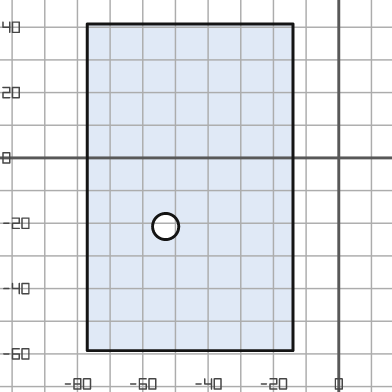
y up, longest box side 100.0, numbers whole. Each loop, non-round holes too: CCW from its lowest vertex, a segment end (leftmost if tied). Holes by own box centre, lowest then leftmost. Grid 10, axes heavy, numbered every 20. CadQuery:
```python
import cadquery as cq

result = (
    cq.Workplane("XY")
    .moveTo(-77.0, -59.0)
    .lineTo(-14.0, -59.0)
    .lineTo(-14.0, 41.0)
    .lineTo(-77.0, 41.0)
    .close()
    .moveTo(-53.0, -21.0)
    .circle(4.0)
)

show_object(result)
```